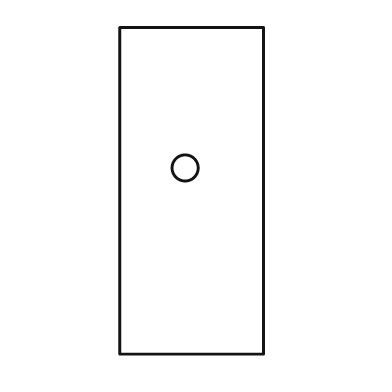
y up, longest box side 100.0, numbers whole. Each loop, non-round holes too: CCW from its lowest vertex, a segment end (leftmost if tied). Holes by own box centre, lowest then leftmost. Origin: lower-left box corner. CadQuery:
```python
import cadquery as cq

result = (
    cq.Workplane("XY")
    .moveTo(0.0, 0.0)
    .lineTo(44.0, 0.0)
    .lineTo(44.0, 100.0)
    .lineTo(0.0, 100.0)
    .close()
    .moveTo(20.0, 57.0)
    .circle(4.0)
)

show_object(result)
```